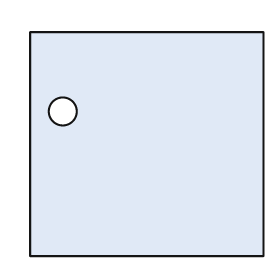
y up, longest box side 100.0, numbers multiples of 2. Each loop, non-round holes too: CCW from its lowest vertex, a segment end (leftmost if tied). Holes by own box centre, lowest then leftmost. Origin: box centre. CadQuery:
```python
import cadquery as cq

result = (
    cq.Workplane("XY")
    .moveTo(-50.0, -48.0)
    .lineTo(50.0, -48.0)
    .lineTo(50.0, 48.0)
    .lineTo(-50.0, 48.0)
    .close()
    .moveTo(-36.0, 14.0)
    .circle(6.0)
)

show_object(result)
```